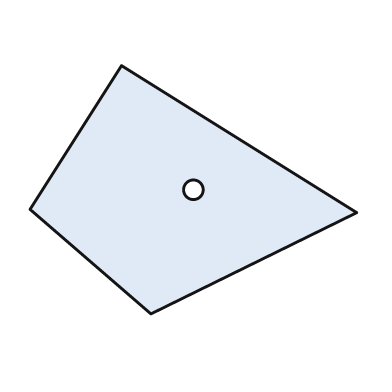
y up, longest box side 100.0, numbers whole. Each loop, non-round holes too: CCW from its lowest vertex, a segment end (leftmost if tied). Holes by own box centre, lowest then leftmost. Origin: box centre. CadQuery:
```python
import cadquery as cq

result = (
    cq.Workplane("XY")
    .moveTo(-13.0, -38.0)
    .lineTo(50.0, -7.0)
    .lineTo(-22.0, 38.0)
    .lineTo(-50.0, -6.0)
    .close()
    .moveTo(0.0, 0.0)
    .circle(3.0)
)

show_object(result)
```